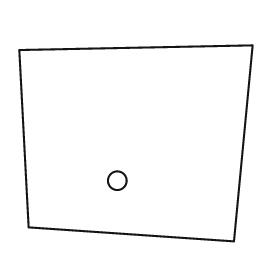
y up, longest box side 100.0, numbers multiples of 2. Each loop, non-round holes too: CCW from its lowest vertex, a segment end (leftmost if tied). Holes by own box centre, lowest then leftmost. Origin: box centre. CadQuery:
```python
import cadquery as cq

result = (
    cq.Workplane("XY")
    .moveTo(42.0, -42.0)
    .lineTo(50.0, 42.0)
    .lineTo(-50.0, 40.0)
    .lineTo(-46.0, -36.0)
    .close()
    .moveTo(-8.0, -16.0)
    .circle(4.0)
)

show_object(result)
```